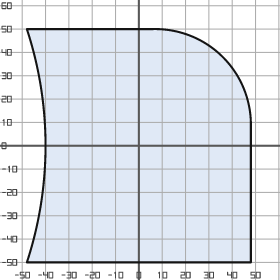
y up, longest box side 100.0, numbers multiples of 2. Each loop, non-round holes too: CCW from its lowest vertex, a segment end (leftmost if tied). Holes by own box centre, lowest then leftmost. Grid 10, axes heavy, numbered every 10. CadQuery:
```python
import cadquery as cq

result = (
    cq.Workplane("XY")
    .moveTo(-48.0, -50.0)
    .lineTo(48.0, -50.0)
    .lineTo(48.0, 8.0)
    .threePointArc((36.0, 38.0), (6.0, 50.0))
    .lineTo(-48.0, 50.0)
    .threePointArc((-40.0, 0.0), (-48.0, -50.0))
    .close()
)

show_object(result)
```